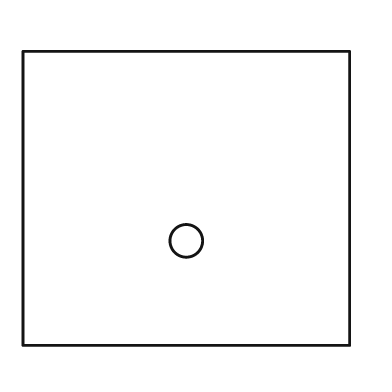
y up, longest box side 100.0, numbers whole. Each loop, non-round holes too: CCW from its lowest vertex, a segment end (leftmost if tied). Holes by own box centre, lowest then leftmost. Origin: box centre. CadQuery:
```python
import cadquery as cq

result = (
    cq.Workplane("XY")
    .moveTo(-50.0, -45.0)
    .lineTo(50.0, -45.0)
    .lineTo(50.0, 45.0)
    .lineTo(-50.0, 45.0)
    .close()
    .moveTo(0.0, -13.0)
    .circle(5.0)
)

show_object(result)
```